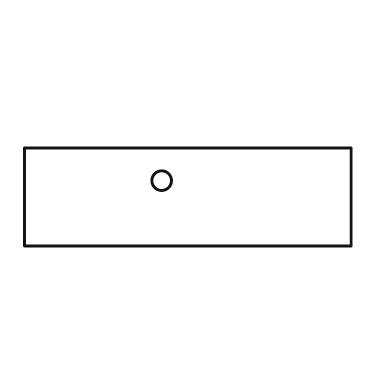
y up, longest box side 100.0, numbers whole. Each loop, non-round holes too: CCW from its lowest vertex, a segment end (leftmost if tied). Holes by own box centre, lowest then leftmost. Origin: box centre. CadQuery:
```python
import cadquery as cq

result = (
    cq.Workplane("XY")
    .moveTo(-50.0, -15.0)
    .lineTo(50.0, -15.0)
    .lineTo(50.0, 15.0)
    .lineTo(-50.0, 15.0)
    .close()
    .moveTo(-8.0, 5.0)
    .circle(3.0)
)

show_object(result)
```